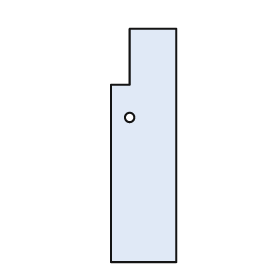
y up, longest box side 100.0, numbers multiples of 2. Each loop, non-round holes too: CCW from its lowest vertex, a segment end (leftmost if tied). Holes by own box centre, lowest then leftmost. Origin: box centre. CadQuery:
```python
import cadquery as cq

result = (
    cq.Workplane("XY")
    .moveTo(-14.0, -50.0)
    .lineTo(14.0, -50.0)
    .lineTo(14.0, 50.0)
    .lineTo(-6.0, 50.0)
    .lineTo(-6.0, 26.0)
    .lineTo(-14.0, 26.0)
    .close()
    .moveTo(-6.0, 12.0)
    .circle(2.0)
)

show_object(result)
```